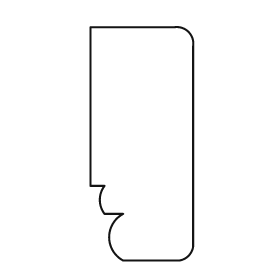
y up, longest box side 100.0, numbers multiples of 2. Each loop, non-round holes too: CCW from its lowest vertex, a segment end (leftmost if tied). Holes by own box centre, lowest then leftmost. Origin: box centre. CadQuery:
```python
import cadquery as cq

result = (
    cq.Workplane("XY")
    .moveTo(-8.0, -50.0)
    .lineTo(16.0, -50.0)
    .threePointArc((20.0, -48.0), (22.0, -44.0))
    .lineTo(22.0, 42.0)
    .threePointArc((20.0, 48.0), (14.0, 50.0))
    .lineTo(-22.0, 50.0)
    .lineTo(-22.0, -18.0)
    .lineTo(-16.0, -18.0)
    .threePointArc((-18.0, -24.0), (-16.0, -30.0))
    .lineTo(-8.0, -30.0)
    .threePointArc((-14.0, -40.0), (-8.0, -50.0))
    .close()
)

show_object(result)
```